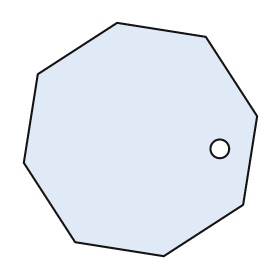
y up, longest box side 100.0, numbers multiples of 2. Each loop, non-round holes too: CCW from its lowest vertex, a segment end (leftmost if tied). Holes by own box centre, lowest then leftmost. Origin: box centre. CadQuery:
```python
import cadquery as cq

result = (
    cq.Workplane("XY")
    .moveTo(10.0, -50.0)
    .lineTo(44.0, -28.0)
    .lineTo(50.0, 10.0)
    .lineTo(28.0, 44.0)
    .lineTo(-10.0, 50.0)
    .lineTo(-44.0, 28.0)
    .lineTo(-50.0, -10.0)
    .lineTo(-28.0, -44.0)
    .close()
    .moveTo(34.0, -4.0)
    .circle(4.0)
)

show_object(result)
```